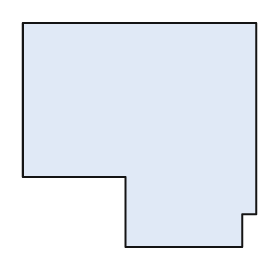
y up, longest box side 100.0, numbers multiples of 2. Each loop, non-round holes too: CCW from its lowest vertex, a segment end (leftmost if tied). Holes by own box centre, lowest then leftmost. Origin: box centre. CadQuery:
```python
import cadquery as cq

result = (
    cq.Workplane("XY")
    .moveTo(-6.0, -48.0)
    .lineTo(44.0, -48.0)
    .lineTo(44.0, -34.0)
    .lineTo(50.0, -34.0)
    .lineTo(50.0, 48.0)
    .lineTo(-50.0, 48.0)
    .lineTo(-50.0, -18.0)
    .lineTo(-6.0, -18.0)
    .close()
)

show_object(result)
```